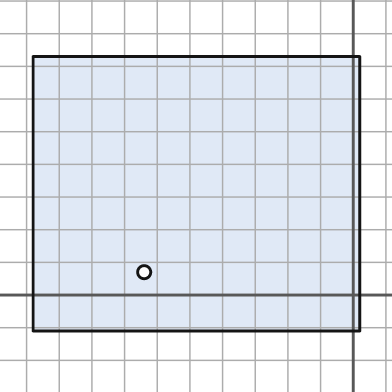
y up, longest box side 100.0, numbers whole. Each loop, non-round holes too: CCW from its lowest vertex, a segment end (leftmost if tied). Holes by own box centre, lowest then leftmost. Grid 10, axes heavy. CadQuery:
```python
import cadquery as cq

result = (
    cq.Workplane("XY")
    .moveTo(-98.0, -11.0)
    .lineTo(2.0, -11.0)
    .lineTo(2.0, 73.0)
    .lineTo(-98.0, 73.0)
    .close()
    .moveTo(-64.0, 7.0)
    .circle(2.0)
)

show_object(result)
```